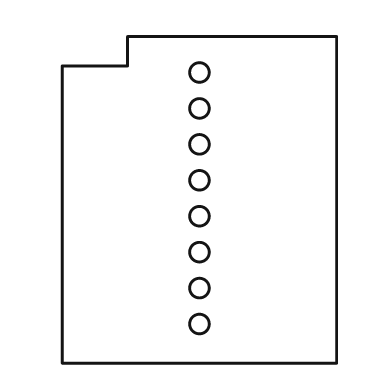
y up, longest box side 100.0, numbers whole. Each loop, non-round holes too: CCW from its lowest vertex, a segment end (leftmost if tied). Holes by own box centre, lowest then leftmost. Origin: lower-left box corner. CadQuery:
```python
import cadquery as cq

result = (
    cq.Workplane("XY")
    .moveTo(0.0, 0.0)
    .lineTo(84.0, 0.0)
    .lineTo(84.0, 100.0)
    .lineTo(20.0, 100.0)
    .lineTo(20.0, 91.0)
    .lineTo(0.0, 91.0)
    .close()
    .moveTo(42.0, 12.0)
    .circle(3.0)
    .moveTo(42.0, 23.0)
    .circle(3.0)
    .moveTo(42.0, 34.0)
    .circle(3.0)
    .moveTo(42.0, 45.0)
    .circle(3.0)
    .moveTo(42.0, 56.0)
    .circle(3.0)
    .moveTo(42.0, 67.0)
    .circle(3.0)
    .moveTo(42.0, 78.0)
    .circle(3.0)
    .moveTo(42.0, 89.0)
    .circle(3.0)
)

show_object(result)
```